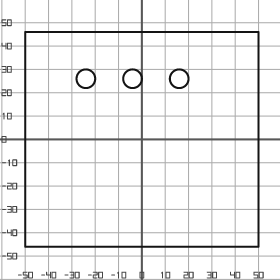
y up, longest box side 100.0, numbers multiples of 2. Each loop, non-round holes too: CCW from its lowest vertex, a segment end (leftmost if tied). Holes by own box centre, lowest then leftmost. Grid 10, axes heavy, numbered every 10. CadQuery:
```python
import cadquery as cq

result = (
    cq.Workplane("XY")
    .moveTo(-50.0, -46.0)
    .lineTo(50.0, -46.0)
    .lineTo(50.0, 46.0)
    .lineTo(-50.0, 46.0)
    .close()
    .moveTo(-24.0, 26.0)
    .circle(4.0)
    .moveTo(-4.0, 26.0)
    .circle(4.0)
    .moveTo(16.0, 26.0)
    .circle(4.0)
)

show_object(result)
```